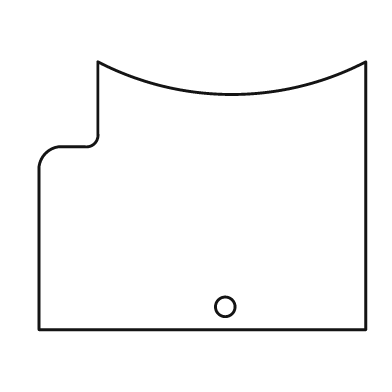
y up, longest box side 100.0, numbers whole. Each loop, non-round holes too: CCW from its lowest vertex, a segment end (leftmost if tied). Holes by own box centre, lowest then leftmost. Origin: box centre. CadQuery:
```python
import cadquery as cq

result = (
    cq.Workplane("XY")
    .moveTo(-50.0, -41.0)
    .lineTo(50.0, -41.0)
    .lineTo(50.0, 41.0)
    .threePointArc((9.0, 31.0), (-32.0, 41.0))
    .lineTo(-32.0, 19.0)
    .threePointArc((-33.0, 16.0), (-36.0, 15.0))
    .lineTo(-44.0, 15.0)
    .threePointArc((-48.0, 13.0), (-50.0, 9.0))
    .close()
    .moveTo(7.0, -34.0)
    .circle(3.0)
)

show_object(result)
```